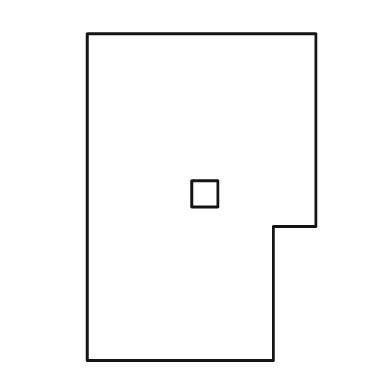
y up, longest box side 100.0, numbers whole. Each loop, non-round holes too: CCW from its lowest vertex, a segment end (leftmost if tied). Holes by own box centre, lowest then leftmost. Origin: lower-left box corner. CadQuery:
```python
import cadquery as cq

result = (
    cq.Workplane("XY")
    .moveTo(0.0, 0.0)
    .lineTo(57.0, 0.0)
    .lineTo(57.0, 41.0)
    .lineTo(70.0, 41.0)
    .lineTo(70.0, 100.0)
    .lineTo(0.0, 100.0)
    .close()
    .moveTo(32.0, 47.0)
    .lineTo(40.0, 47.0)
    .lineTo(40.0, 55.0)
    .lineTo(32.0, 55.0)
    .close()
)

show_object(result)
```